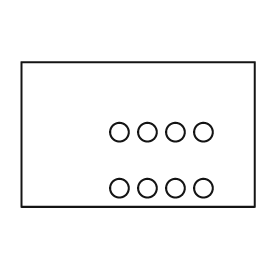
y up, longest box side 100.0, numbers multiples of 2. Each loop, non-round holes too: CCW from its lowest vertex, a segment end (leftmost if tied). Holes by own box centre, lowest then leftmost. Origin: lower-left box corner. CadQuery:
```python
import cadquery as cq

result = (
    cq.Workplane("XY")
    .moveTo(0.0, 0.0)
    .lineTo(100.0, 0.0)
    .lineTo(100.0, 62.0)
    .lineTo(0.0, 62.0)
    .close()
    .moveTo(42.0, 8.0)
    .circle(4.0)
    .moveTo(54.0, 8.0)
    .circle(4.0)
    .moveTo(66.0, 8.0)
    .circle(4.0)
    .moveTo(78.0, 8.0)
    .circle(4.0)
    .moveTo(42.0, 32.0)
    .circle(4.0)
    .moveTo(54.0, 32.0)
    .circle(4.0)
    .moveTo(66.0, 32.0)
    .circle(4.0)
    .moveTo(78.0, 32.0)
    .circle(4.0)
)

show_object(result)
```